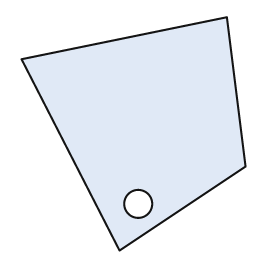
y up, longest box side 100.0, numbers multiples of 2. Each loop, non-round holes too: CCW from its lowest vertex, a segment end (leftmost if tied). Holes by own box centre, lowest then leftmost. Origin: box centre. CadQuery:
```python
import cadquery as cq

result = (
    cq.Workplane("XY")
    .moveTo(-6.0, -50.0)
    .lineTo(48.0, -14.0)
    .lineTo(40.0, 50.0)
    .lineTo(-48.0, 32.0)
    .close()
    .moveTo(2.0, -30.0)
    .circle(6.0)
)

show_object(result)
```